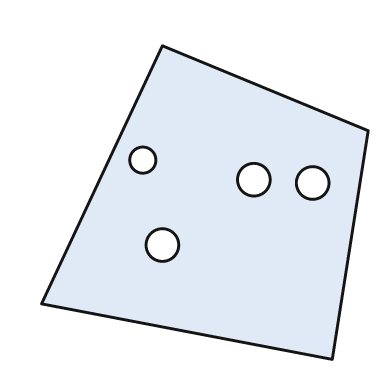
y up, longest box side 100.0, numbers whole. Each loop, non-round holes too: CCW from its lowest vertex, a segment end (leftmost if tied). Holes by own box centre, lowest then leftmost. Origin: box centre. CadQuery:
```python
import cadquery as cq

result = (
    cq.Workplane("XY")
    .moveTo(39.0, -48.0)
    .lineTo(50.0, 22.0)
    .lineTo(-13.0, 48.0)
    .lineTo(-50.0, -31.0)
    .close()
    .moveTo(-13.0, -13.0)
    .circle(5.0)
    .moveTo(33.0, 6.0)
    .circle(5.0)
    .moveTo(15.0, 7.0)
    .circle(5.0)
    .moveTo(-19.0, 13.0)
    .circle(4.0)
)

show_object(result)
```